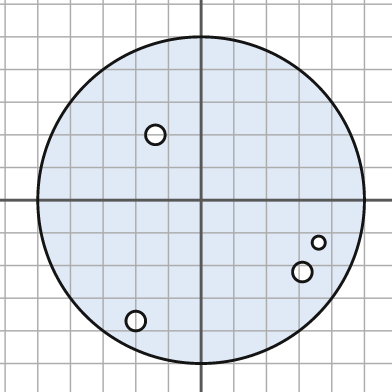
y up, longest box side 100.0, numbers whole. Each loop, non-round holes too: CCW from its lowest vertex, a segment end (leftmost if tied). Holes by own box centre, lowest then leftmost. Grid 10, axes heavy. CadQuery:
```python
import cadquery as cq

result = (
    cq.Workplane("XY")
    .moveTo(0.0, 0.0)
    .circle(50.0)
    .moveTo(-20.0, -37.0)
    .circle(3.0)
    .moveTo(31.0, -22.0)
    .circle(3.0)
    .moveTo(36.0, -13.0)
    .circle(2.0)
    .moveTo(-14.0, 20.0)
    .circle(3.0)
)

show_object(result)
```